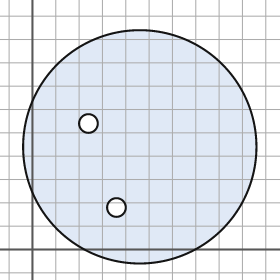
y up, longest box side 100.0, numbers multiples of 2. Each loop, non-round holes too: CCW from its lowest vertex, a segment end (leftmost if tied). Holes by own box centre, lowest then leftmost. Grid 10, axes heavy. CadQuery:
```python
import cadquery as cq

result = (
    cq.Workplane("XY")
    .moveTo(46.0, 44.0)
    .circle(50.0)
    .moveTo(36.0, 18.0)
    .circle(4.0)
    .moveTo(24.0, 54.0)
    .circle(4.0)
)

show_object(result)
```